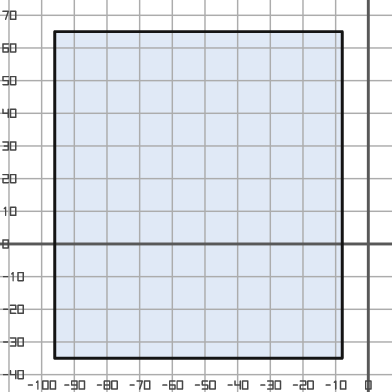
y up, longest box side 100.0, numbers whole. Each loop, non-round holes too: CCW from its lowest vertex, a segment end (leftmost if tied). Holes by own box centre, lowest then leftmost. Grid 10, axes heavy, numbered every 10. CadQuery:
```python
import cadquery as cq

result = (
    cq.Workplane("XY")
    .moveTo(-96.0, -35.0)
    .lineTo(-8.0, -35.0)
    .lineTo(-8.0, 65.0)
    .lineTo(-96.0, 65.0)
    .close()
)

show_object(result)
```